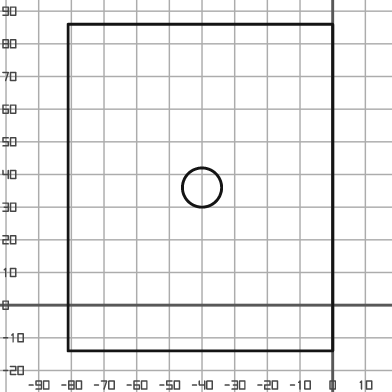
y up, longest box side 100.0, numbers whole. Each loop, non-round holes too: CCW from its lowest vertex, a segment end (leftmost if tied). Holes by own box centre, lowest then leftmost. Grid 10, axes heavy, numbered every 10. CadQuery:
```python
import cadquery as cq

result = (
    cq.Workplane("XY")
    .moveTo(-81.0, -14.0)
    .lineTo(0.0, -14.0)
    .lineTo(0.0, 86.0)
    .lineTo(-81.0, 86.0)
    .close()
    .moveTo(-40.0, 36.0)
    .circle(6.0)
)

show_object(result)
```